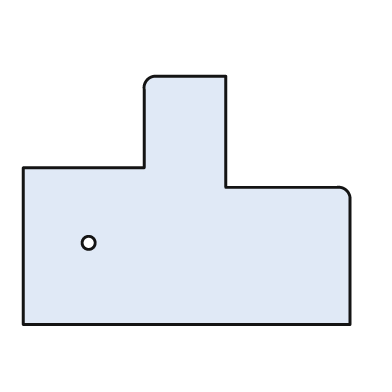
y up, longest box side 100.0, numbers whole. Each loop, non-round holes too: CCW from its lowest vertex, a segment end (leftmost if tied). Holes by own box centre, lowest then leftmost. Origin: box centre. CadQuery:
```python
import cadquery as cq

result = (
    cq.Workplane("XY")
    .moveTo(-50.0, -38.0)
    .lineTo(50.0, -38.0)
    .lineTo(50.0, 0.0)
    .threePointArc((49.0, 3.0), (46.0, 4.0))
    .lineTo(12.0, 4.0)
    .lineTo(12.0, 38.0)
    .lineTo(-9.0, 38.0)
    .threePointArc((-12.0, 37.0), (-13.0, 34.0))
    .lineTo(-13.0, 10.0)
    .lineTo(-50.0, 10.0)
    .close()
    .moveTo(-30.0, -13.0)
    .circle(2.0)
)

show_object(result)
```